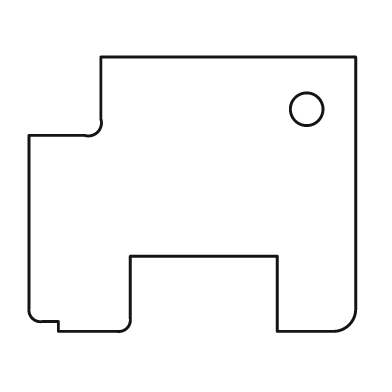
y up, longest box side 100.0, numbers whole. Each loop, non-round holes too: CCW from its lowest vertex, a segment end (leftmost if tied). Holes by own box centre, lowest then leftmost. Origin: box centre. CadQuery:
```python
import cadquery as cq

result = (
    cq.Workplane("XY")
    .moveTo(-41.0, -42.0)
    .lineTo(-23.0, -42.0)
    .threePointArc((-20.0, -41.0), (-19.0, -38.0))
    .lineTo(-19.0, -19.0)
    .lineTo(26.0, -19.0)
    .lineTo(26.0, -42.0)
    .lineTo(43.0, -42.0)
    .threePointArc((48.0, -40.0), (50.0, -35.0))
    .lineTo(50.0, 42.0)
    .lineTo(-28.0, 42.0)
    .lineTo(-28.0, 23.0)
    .threePointArc((-29.0, 19.0), (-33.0, 18.0))
    .lineTo(-50.0, 18.0)
    .lineTo(-50.0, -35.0)
    .threePointArc((-49.0, -38.0), (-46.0, -39.0))
    .lineTo(-41.0, -39.0)
    .close()
    .moveTo(35.0, 26.0)
    .circle(5.0)
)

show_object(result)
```